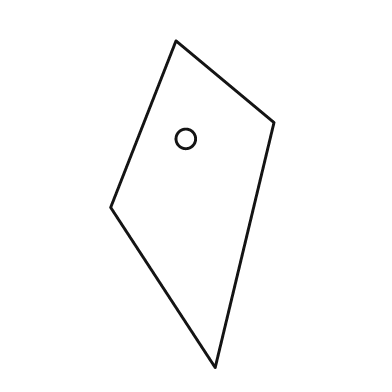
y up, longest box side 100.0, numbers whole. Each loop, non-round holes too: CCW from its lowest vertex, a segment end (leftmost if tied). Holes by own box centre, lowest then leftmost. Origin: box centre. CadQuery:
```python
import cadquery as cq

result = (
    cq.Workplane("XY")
    .moveTo(7.0, -50.0)
    .lineTo(25.0, 25.0)
    .lineTo(-5.0, 50.0)
    .lineTo(-25.0, -1.0)
    .close()
    .moveTo(-2.0, 20.0)
    .circle(3.0)
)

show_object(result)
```